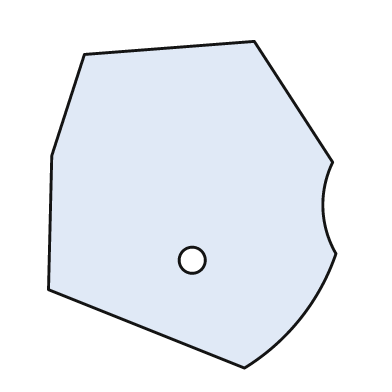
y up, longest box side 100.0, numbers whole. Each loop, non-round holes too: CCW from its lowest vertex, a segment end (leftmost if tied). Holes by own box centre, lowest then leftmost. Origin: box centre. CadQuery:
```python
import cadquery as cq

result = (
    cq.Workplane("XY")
    .moveTo(16.0, -50.0)
    .threePointArc((33.0, -35.0), (44.0, -15.0))
    .threePointArc((40.0, -1.0), (43.0, 13.0))
    .lineTo(19.0, 50.0)
    .lineTo(-33.0, 46.0)
    .lineTo(-43.0, 15.0)
    .lineTo(-44.0, -26.0)
    .close()
    .moveTo(0.0, -17.0)
    .circle(4.0)
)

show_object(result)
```